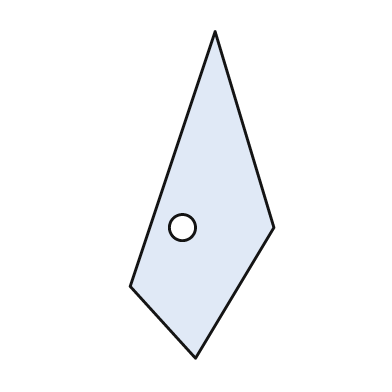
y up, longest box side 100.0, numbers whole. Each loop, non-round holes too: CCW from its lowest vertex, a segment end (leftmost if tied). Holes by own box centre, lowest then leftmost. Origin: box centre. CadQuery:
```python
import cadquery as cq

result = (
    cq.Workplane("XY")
    .moveTo(-2.0, -50.0)
    .lineTo(22.0, -10.0)
    .lineTo(4.0, 50.0)
    .lineTo(-22.0, -28.0)
    .close()
    .moveTo(-6.0, -10.0)
    .circle(4.0)
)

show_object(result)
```